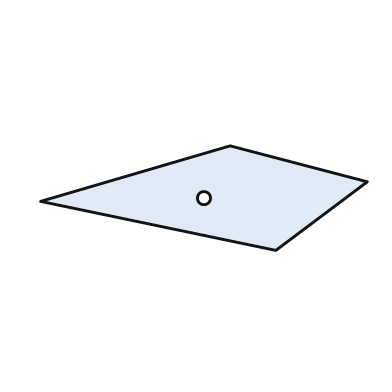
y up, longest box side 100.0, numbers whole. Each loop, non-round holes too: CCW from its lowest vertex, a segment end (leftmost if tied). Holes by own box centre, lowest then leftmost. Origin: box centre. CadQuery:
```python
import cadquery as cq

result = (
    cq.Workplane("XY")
    .moveTo(22.0, -16.0)
    .lineTo(50.0, 5.0)
    .lineTo(8.0, 16.0)
    .lineTo(-50.0, -1.0)
    .close()
    .moveTo(0.0, 0.0)
    .circle(2.0)
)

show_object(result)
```